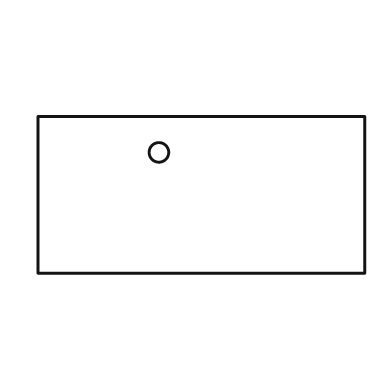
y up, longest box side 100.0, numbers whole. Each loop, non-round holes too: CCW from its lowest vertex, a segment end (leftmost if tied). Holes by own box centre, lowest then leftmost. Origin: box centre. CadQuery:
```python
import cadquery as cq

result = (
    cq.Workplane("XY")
    .moveTo(-50.0, -24.0)
    .lineTo(50.0, -24.0)
    .lineTo(50.0, 24.0)
    .lineTo(-50.0, 24.0)
    .close()
    .moveTo(-13.0, 13.0)
    .circle(3.0)
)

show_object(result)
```